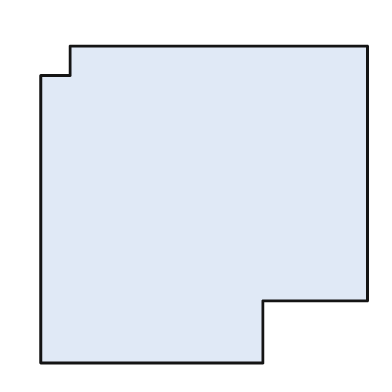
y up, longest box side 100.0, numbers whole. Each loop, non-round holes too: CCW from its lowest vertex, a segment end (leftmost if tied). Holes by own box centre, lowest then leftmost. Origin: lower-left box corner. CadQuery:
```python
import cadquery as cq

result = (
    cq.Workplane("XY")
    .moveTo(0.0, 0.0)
    .lineTo(68.0, 0.0)
    .lineTo(68.0, 19.0)
    .lineTo(100.0, 19.0)
    .lineTo(100.0, 97.0)
    .lineTo(9.0, 97.0)
    .lineTo(9.0, 88.0)
    .lineTo(0.0, 88.0)
    .close()
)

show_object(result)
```